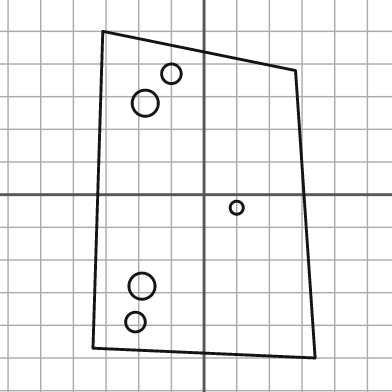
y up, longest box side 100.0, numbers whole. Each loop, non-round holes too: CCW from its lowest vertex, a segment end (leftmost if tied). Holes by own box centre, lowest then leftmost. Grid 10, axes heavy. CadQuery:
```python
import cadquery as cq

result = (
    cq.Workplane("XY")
    .moveTo(34.0, -50.0)
    .lineTo(28.0, 38.0)
    .lineTo(-31.0, 50.0)
    .lineTo(-34.0, -47.0)
    .close()
    .moveTo(-21.0, -39.0)
    .circle(3.0)
    .moveTo(-19.0, -28.0)
    .circle(4.0)
    .moveTo(10.0, -4.0)
    .circle(2.0)
    .moveTo(-18.0, 28.0)
    .circle(4.0)
    .moveTo(-10.0, 37.0)
    .circle(3.0)
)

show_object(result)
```